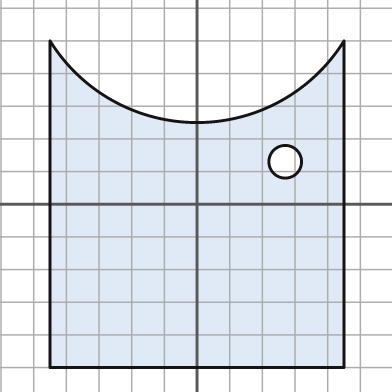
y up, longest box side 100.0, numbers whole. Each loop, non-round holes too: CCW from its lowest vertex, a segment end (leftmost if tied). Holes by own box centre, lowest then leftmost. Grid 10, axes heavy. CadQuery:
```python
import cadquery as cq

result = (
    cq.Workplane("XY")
    .moveTo(-45.0, -50.0)
    .lineTo(45.0, -50.0)
    .lineTo(45.0, 50.0)
    .threePointArc((0.0, 25.0), (-45.0, 50.0))
    .close()
    .moveTo(27.0, 13.0)
    .circle(5.0)
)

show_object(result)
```